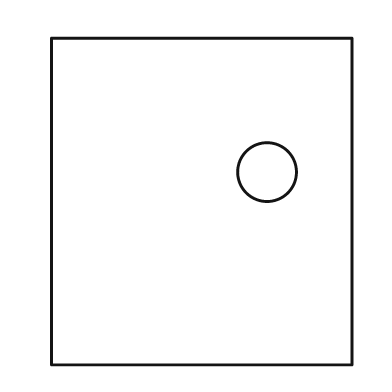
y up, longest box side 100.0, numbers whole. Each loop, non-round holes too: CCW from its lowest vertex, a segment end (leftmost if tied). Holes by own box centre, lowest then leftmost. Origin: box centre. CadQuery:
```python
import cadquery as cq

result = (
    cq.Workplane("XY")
    .moveTo(-46.0, -50.0)
    .lineTo(46.0, -50.0)
    .lineTo(46.0, 50.0)
    .lineTo(-46.0, 50.0)
    .close()
    .moveTo(20.0, 9.0)
    .circle(9.0)
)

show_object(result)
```